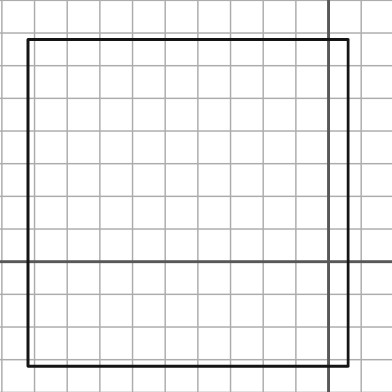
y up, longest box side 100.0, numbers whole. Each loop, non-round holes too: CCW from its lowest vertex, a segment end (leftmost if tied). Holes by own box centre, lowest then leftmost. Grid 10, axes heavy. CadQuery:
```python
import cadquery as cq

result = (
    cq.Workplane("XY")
    .moveTo(-92.0, -32.0)
    .lineTo(6.0, -32.0)
    .lineTo(6.0, 68.0)
    .lineTo(-92.0, 68.0)
    .close()
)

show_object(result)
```